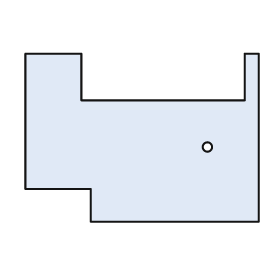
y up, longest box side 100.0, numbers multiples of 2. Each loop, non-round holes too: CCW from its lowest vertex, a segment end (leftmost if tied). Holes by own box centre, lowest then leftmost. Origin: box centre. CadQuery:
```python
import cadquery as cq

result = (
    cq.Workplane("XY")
    .moveTo(-22.0, -36.0)
    .lineTo(50.0, -36.0)
    .lineTo(50.0, 36.0)
    .lineTo(44.0, 36.0)
    .lineTo(44.0, 16.0)
    .lineTo(-26.0, 16.0)
    .lineTo(-26.0, 36.0)
    .lineTo(-50.0, 36.0)
    .lineTo(-50.0, -22.0)
    .lineTo(-22.0, -22.0)
    .close()
    .moveTo(28.0, -4.0)
    .circle(2.0)
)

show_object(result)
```